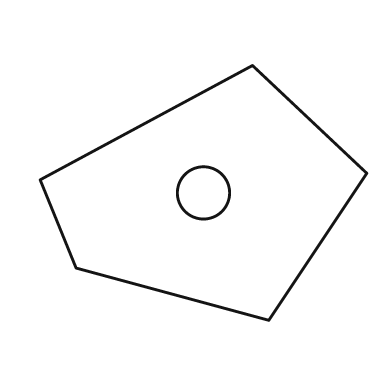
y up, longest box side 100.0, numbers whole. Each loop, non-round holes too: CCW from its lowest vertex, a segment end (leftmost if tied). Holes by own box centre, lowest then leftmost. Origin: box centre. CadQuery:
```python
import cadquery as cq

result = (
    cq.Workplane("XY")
    .moveTo(20.0, -39.0)
    .lineTo(50.0, 6.0)
    .lineTo(15.0, 39.0)
    .lineTo(-50.0, 4.0)
    .lineTo(-39.0, -23.0)
    .close()
    .moveTo(0.0, 0.0)
    .circle(8.0)
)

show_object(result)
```